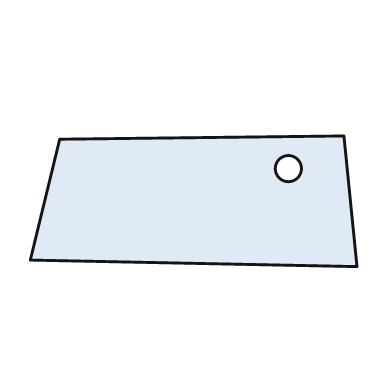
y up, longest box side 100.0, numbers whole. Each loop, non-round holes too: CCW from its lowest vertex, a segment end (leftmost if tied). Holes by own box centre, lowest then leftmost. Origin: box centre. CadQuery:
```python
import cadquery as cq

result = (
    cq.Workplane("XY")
    .moveTo(50.0, -20.0)
    .lineTo(46.0, 20.0)
    .lineTo(-41.0, 19.0)
    .lineTo(-50.0, -18.0)
    .close()
    .moveTo(29.0, 10.0)
    .circle(4.0)
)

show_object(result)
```